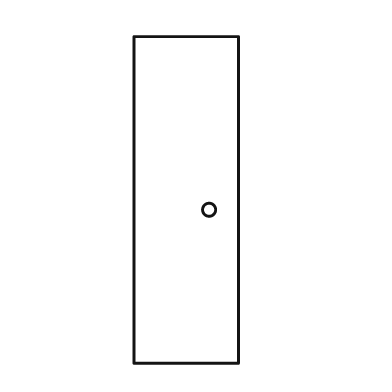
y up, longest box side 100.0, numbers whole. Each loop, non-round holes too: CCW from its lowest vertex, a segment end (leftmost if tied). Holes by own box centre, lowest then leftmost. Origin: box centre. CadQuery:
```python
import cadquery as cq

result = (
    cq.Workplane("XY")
    .moveTo(-16.0, -50.0)
    .lineTo(16.0, -50.0)
    .lineTo(16.0, 50.0)
    .lineTo(-16.0, 50.0)
    .close()
    .moveTo(7.0, -3.0)
    .circle(2.0)
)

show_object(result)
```